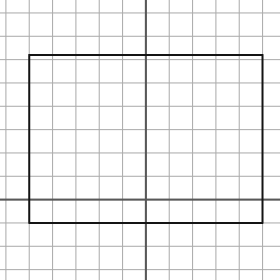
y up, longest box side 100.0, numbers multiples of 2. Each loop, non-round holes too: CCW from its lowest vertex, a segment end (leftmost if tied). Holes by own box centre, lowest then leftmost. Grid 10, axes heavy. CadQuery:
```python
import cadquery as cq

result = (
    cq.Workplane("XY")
    .moveTo(-50.0, -10.0)
    .lineTo(50.0, -10.0)
    .lineTo(50.0, 62.0)
    .lineTo(-50.0, 62.0)
    .close()
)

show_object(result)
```